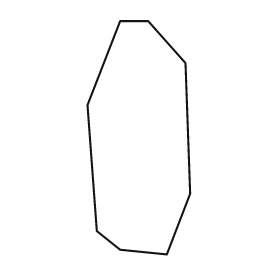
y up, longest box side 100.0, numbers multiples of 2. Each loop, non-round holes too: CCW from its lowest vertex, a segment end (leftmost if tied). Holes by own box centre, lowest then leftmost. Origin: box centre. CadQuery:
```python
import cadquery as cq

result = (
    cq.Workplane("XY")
    .moveTo(12.0, -50.0)
    .lineTo(22.0, -24.0)
    .lineTo(20.0, 32.0)
    .lineTo(4.0, 50.0)
    .lineTo(-8.0, 50.0)
    .lineTo(-22.0, 14.0)
    .lineTo(-18.0, -40.0)
    .lineTo(-8.0, -48.0)
    .close()
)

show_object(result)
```